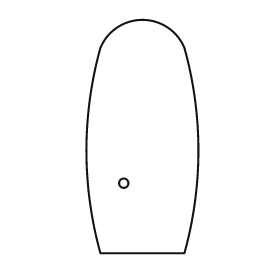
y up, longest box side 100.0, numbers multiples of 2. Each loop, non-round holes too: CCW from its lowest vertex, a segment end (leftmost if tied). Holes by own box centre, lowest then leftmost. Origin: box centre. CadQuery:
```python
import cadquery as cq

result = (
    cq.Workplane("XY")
    .moveTo(-18.0, -50.0)
    .lineTo(18.0, -50.0)
    .threePointArc((24.0, -6.0), (18.0, 38.0))
    .threePointArc((0.0, 50.0), (-18.0, 38.0))
    .threePointArc((-24.0, -6.0), (-18.0, -50.0))
    .close()
    .moveTo(-8.0, -20.0)
    .circle(2.0)
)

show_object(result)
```